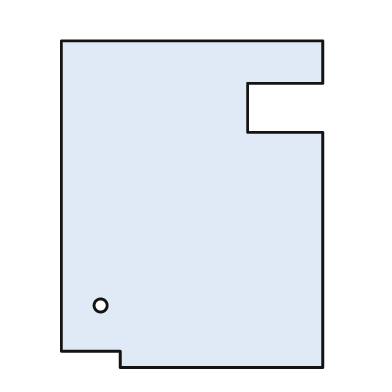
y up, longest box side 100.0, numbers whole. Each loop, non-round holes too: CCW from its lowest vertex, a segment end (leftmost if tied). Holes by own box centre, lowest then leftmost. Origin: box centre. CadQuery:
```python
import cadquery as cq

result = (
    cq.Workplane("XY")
    .moveTo(-22.0, -50.0)
    .lineTo(40.0, -50.0)
    .lineTo(40.0, 22.0)
    .lineTo(17.0, 22.0)
    .lineTo(17.0, 37.0)
    .lineTo(40.0, 37.0)
    .lineTo(40.0, 50.0)
    .lineTo(-40.0, 50.0)
    .lineTo(-40.0, -45.0)
    .lineTo(-22.0, -45.0)
    .close()
    .moveTo(-28.0, -31.0)
    .circle(2.0)
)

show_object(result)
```